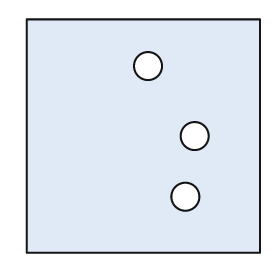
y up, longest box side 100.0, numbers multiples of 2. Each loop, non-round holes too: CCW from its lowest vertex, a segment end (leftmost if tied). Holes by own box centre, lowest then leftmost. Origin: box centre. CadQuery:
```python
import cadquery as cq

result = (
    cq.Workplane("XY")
    .moveTo(-50.0, -50.0)
    .lineTo(50.0, -50.0)
    .lineTo(50.0, 50.0)
    .lineTo(-50.0, 50.0)
    .close()
    .moveTo(18.0, -26.0)
    .circle(6.0)
    .moveTo(22.0, 0.0)
    .circle(6.0)
    .moveTo(2.0, 30.0)
    .circle(6.0)
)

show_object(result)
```